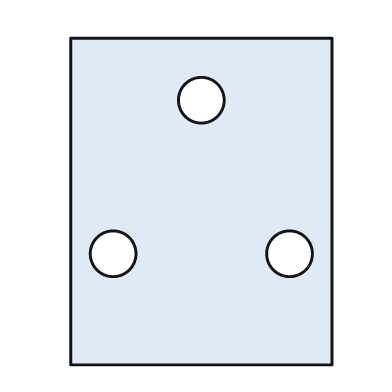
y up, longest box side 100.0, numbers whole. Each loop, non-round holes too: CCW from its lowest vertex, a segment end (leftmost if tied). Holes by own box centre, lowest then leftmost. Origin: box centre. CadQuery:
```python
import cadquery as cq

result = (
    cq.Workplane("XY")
    .moveTo(-40.0, -50.0)
    .lineTo(40.0, -50.0)
    .lineTo(40.0, 50.0)
    .lineTo(-40.0, 50.0)
    .close()
    .moveTo(-27.0, -16.0)
    .circle(7.0)
    .moveTo(27.0, -16.0)
    .circle(7.0)
    .moveTo(0.0, 31.0)
    .circle(7.0)
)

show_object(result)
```